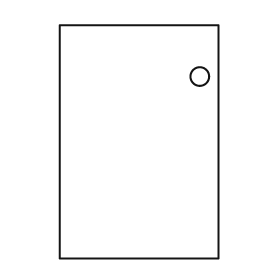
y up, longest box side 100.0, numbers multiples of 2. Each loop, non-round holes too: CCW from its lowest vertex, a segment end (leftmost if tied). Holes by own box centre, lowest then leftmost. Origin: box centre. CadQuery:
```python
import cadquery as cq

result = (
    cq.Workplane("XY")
    .moveTo(-34.0, -50.0)
    .lineTo(34.0, -50.0)
    .lineTo(34.0, 50.0)
    .lineTo(-34.0, 50.0)
    .close()
    .moveTo(26.0, 28.0)
    .circle(4.0)
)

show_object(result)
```